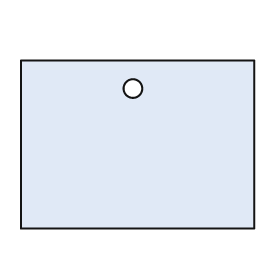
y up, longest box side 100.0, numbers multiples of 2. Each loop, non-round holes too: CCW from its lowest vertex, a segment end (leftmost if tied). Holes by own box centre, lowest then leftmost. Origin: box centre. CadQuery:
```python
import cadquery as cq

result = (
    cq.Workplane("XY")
    .moveTo(-50.0, -36.0)
    .lineTo(50.0, -36.0)
    .lineTo(50.0, 36.0)
    .lineTo(-50.0, 36.0)
    .close()
    .moveTo(-2.0, 24.0)
    .circle(4.0)
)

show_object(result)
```